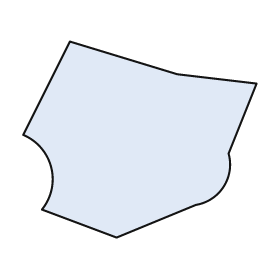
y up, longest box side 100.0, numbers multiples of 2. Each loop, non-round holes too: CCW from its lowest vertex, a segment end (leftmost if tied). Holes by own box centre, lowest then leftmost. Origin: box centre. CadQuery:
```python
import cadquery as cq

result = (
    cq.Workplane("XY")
    .moveTo(-10.0, -42.0)
    .lineTo(24.0, -28.0)
    .threePointArc((36.0, -20.0), (38.0, -6.0))
    .lineTo(50.0, 24.0)
    .lineTo(16.0, 28.0)
    .lineTo(-30.0, 42.0)
    .lineTo(-50.0, 2.0)
    .threePointArc((-38.0, -12.0), (-42.0, -30.0))
    .close()
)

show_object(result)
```